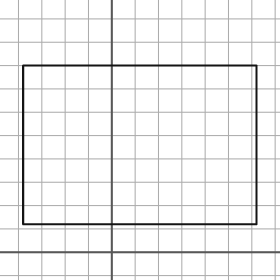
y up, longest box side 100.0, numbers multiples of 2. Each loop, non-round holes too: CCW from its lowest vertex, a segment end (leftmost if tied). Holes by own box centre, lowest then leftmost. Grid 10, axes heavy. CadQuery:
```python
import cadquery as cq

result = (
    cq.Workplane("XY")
    .moveTo(-38.0, 12.0)
    .lineTo(62.0, 12.0)
    .lineTo(62.0, 80.0)
    .lineTo(-38.0, 80.0)
    .close()
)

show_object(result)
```